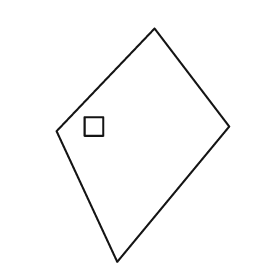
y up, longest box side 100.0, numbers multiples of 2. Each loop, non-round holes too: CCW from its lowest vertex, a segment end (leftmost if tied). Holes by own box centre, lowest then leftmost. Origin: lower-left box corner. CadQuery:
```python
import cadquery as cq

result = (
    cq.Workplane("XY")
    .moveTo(26.0, 0.0)
    .lineTo(74.0, 58.0)
    .lineTo(42.0, 100.0)
    .lineTo(0.0, 56.0)
    .close()
    .moveTo(12.0, 54.0)
    .lineTo(20.0, 54.0)
    .lineTo(20.0, 62.0)
    .lineTo(12.0, 62.0)
    .close()
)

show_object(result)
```